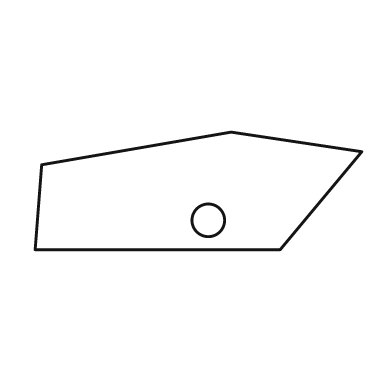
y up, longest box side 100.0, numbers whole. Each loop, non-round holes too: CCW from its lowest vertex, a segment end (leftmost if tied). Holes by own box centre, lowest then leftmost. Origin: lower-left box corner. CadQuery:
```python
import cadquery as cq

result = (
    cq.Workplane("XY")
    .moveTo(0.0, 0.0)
    .lineTo(75.0, 0.0)
    .lineTo(100.0, 30.0)
    .lineTo(60.0, 36.0)
    .lineTo(2.0, 26.0)
    .close()
    .moveTo(53.0, 9.0)
    .circle(5.0)
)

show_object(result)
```